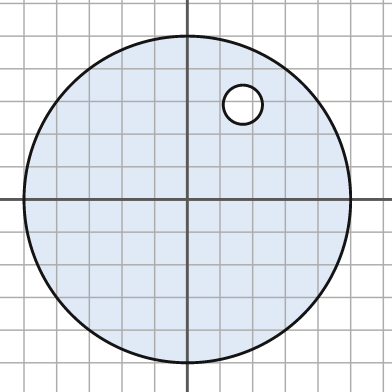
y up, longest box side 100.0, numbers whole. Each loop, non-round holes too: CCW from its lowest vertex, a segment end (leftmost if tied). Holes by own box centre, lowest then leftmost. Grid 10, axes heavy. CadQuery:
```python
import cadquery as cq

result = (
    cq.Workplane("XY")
    .moveTo(0.0, 0.0)
    .circle(50.0)
    .moveTo(17.0, 29.0)
    .circle(6.0)
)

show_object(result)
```